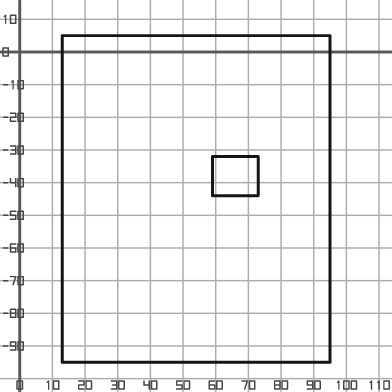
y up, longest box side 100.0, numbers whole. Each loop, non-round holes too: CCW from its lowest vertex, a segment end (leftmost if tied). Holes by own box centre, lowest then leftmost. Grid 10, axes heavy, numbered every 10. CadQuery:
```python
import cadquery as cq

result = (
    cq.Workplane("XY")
    .moveTo(13.0, -95.0)
    .lineTo(95.0, -95.0)
    .lineTo(95.0, 5.0)
    .lineTo(13.0, 5.0)
    .close()
    .moveTo(59.0, -44.0)
    .lineTo(73.0, -44.0)
    .lineTo(73.0, -32.0)
    .lineTo(59.0, -32.0)
    .close()
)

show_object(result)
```